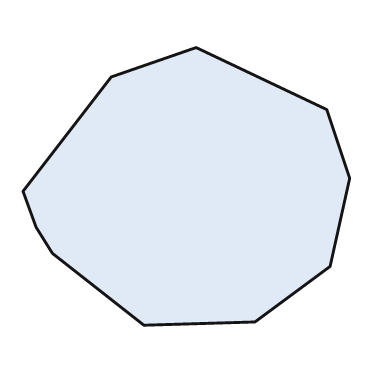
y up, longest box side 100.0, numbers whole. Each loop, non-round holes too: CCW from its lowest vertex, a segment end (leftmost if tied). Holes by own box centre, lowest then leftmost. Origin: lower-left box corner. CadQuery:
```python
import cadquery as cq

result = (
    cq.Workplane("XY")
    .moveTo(37.0, 0.0)
    .lineTo(71.0, 1.0)
    .lineTo(94.0, 18.0)
    .lineTo(100.0, 45.0)
    .lineTo(93.0, 66.0)
    .lineTo(53.0, 85.0)
    .lineTo(27.0, 76.0)
    .lineTo(0.0, 41.0)
    .lineTo(4.0, 30.0)
    .lineTo(9.0, 22.0)
    .close()
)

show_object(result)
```